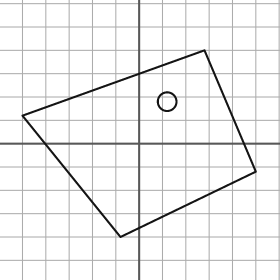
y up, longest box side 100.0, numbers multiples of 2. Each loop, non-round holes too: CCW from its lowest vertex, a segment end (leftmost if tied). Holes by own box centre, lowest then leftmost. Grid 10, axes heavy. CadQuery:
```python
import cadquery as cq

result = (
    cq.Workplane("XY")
    .moveTo(-8.0, -40.0)
    .lineTo(50.0, -12.0)
    .lineTo(28.0, 40.0)
    .lineTo(-50.0, 12.0)
    .close()
    .moveTo(12.0, 18.0)
    .circle(4.0)
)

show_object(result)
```